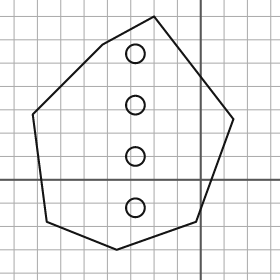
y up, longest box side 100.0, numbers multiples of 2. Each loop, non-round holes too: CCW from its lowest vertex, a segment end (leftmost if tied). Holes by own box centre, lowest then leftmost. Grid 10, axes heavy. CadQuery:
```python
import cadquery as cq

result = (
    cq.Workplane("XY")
    .moveTo(-36.0, -30.0)
    .lineTo(-2.0, -18.0)
    .lineTo(14.0, 26.0)
    .lineTo(-20.0, 70.0)
    .lineTo(-42.0, 58.0)
    .lineTo(-72.0, 28.0)
    .lineTo(-66.0, -18.0)
    .close()
    .moveTo(-28.0, -12.0)
    .circle(4.0)
    .moveTo(-28.0, 10.0)
    .circle(4.0)
    .moveTo(-28.0, 32.0)
    .circle(4.0)
    .moveTo(-28.0, 54.0)
    .circle(4.0)
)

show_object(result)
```